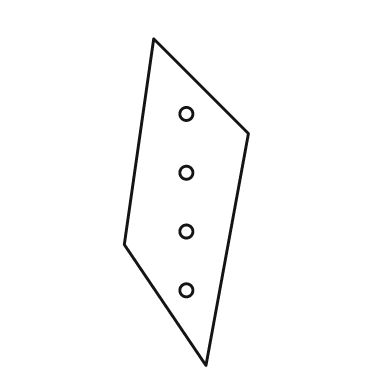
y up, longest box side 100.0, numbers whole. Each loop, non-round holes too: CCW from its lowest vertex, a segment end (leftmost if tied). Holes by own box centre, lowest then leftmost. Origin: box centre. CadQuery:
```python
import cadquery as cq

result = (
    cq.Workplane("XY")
    .moveTo(6.0, -50.0)
    .lineTo(19.0, 21.0)
    .lineTo(-10.0, 50.0)
    .lineTo(-19.0, -13.0)
    .close()
    .moveTo(0.0, -27.0)
    .circle(2.0)
    .moveTo(0.0, -9.0)
    .circle(2.0)
    .moveTo(0.0, 9.0)
    .circle(2.0)
    .moveTo(0.0, 27.0)
    .circle(2.0)
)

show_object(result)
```